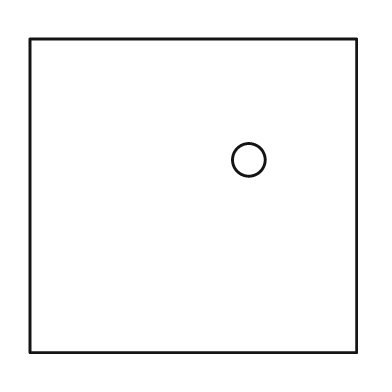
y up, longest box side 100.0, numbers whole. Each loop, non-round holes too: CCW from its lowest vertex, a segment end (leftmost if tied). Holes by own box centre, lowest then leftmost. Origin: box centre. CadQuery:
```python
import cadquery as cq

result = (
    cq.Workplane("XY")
    .moveTo(-50.0, -48.0)
    .lineTo(50.0, -48.0)
    .lineTo(50.0, 48.0)
    .lineTo(-50.0, 48.0)
    .close()
    .moveTo(17.0, 11.0)
    .circle(5.0)
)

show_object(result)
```